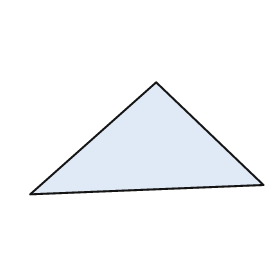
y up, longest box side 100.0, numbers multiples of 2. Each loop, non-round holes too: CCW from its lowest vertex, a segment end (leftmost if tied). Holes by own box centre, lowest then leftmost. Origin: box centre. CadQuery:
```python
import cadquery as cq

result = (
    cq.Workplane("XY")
    .moveTo(-50.0, -24.0)
    .lineTo(50.0, -20.0)
    .lineTo(4.0, 24.0)
    .close()
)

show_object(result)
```